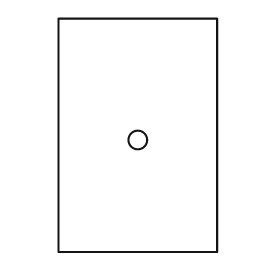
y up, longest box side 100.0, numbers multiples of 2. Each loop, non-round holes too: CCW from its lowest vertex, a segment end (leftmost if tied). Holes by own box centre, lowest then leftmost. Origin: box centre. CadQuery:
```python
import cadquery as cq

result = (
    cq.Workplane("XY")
    .moveTo(-34.0, -50.0)
    .lineTo(34.0, -50.0)
    .lineTo(34.0, 50.0)
    .lineTo(-34.0, 50.0)
    .close()
    .moveTo(0.0, -2.0)
    .circle(4.0)
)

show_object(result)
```